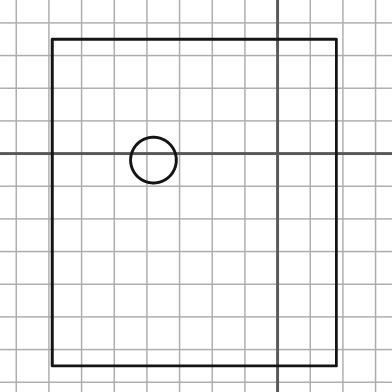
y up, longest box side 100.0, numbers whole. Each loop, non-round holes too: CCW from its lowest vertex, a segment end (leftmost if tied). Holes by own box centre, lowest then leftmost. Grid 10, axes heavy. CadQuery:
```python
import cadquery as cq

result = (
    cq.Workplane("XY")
    .moveTo(-69.0, -65.0)
    .lineTo(18.0, -65.0)
    .lineTo(18.0, 35.0)
    .lineTo(-69.0, 35.0)
    .close()
    .moveTo(-38.0, -2.0)
    .circle(7.0)
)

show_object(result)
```